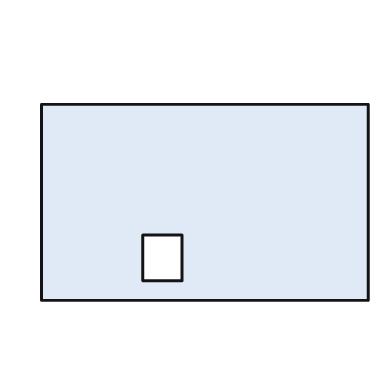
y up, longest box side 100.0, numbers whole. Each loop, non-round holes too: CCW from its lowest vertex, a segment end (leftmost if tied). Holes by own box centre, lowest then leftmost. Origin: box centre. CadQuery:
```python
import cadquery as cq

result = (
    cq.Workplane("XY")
    .moveTo(-50.0, -30.0)
    .lineTo(50.0, -30.0)
    .lineTo(50.0, 30.0)
    .lineTo(-50.0, 30.0)
    .close()
    .moveTo(-19.0, -24.0)
    .lineTo(-7.0, -24.0)
    .lineTo(-7.0, -10.0)
    .lineTo(-19.0, -10.0)
    .close()
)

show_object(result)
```